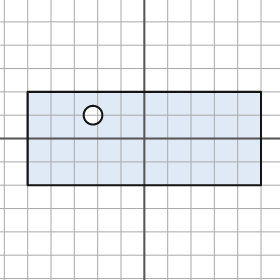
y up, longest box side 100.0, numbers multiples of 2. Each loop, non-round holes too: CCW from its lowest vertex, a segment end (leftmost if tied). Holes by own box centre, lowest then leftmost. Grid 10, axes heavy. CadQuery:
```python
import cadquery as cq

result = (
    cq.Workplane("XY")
    .moveTo(-50.0, -20.0)
    .lineTo(50.0, -20.0)
    .lineTo(50.0, 20.0)
    .lineTo(-50.0, 20.0)
    .close()
    .moveTo(-22.0, 10.0)
    .circle(4.0)
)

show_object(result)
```